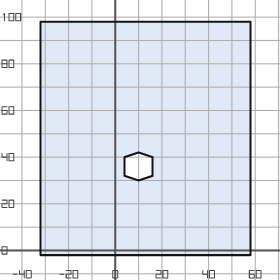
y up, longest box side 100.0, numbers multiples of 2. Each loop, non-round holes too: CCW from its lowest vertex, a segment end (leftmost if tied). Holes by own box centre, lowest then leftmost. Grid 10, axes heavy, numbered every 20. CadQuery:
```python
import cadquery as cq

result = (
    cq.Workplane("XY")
    .moveTo(-32.0, -2.0)
    .lineTo(58.0, -2.0)
    .lineTo(58.0, 98.0)
    .lineTo(-32.0, 98.0)
    .close()
    .moveTo(10.0, 30.0)
    .lineTo(16.0, 32.0)
    .lineTo(16.0, 40.0)
    .lineTo(10.0, 42.0)
    .lineTo(4.0, 40.0)
    .lineTo(4.0, 32.0)
    .close()
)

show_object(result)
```